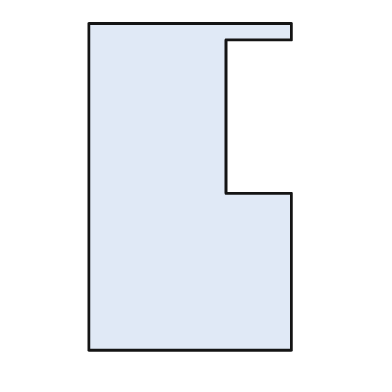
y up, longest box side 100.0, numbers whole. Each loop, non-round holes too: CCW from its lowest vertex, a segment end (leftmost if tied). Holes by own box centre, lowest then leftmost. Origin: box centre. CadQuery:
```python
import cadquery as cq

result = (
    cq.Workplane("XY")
    .moveTo(-31.0, -50.0)
    .lineTo(31.0, -50.0)
    .lineTo(31.0, -2.0)
    .lineTo(11.0, -2.0)
    .lineTo(11.0, 45.0)
    .lineTo(31.0, 45.0)
    .lineTo(31.0, 50.0)
    .lineTo(-31.0, 50.0)
    .close()
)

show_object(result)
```